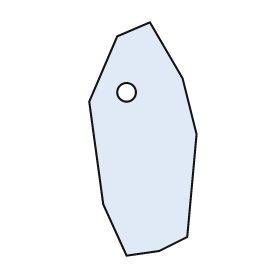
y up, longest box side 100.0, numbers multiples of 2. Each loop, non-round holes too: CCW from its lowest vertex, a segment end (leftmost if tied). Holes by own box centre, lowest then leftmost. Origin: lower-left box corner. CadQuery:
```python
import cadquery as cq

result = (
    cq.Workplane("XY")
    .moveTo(16.0, 0.0)
    .lineTo(30.0, 2.0)
    .lineTo(42.0, 8.0)
    .lineTo(46.0, 52.0)
    .lineTo(40.0, 76.0)
    .lineTo(26.0, 100.0)
    .lineTo(12.0, 94.0)
    .lineTo(0.0, 66.0)
    .lineTo(6.0, 22.0)
    .close()
    .moveTo(16.0, 70.0)
    .circle(4.0)
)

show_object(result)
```